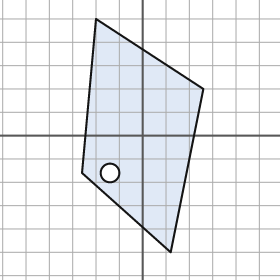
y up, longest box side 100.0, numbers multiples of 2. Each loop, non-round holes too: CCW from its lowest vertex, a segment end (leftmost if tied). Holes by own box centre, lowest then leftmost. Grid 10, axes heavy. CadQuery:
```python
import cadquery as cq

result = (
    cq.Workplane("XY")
    .moveTo(12.0, -50.0)
    .lineTo(26.0, 20.0)
    .lineTo(-20.0, 50.0)
    .lineTo(-26.0, -16.0)
    .close()
    .moveTo(-14.0, -16.0)
    .circle(4.0)
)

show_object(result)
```